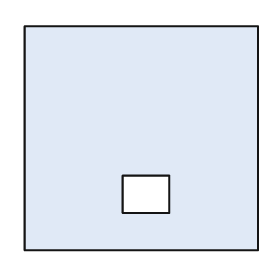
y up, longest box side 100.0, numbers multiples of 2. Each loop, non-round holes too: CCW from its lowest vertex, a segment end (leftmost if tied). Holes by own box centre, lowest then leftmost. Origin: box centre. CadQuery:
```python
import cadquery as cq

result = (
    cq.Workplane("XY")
    .moveTo(-50.0, -48.0)
    .lineTo(50.0, -48.0)
    .lineTo(50.0, 48.0)
    .lineTo(-50.0, 48.0)
    .close()
    .moveTo(-8.0, -32.0)
    .lineTo(12.0, -32.0)
    .lineTo(12.0, -16.0)
    .lineTo(-8.0, -16.0)
    .close()
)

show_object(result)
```